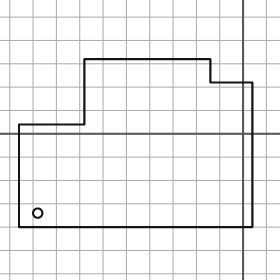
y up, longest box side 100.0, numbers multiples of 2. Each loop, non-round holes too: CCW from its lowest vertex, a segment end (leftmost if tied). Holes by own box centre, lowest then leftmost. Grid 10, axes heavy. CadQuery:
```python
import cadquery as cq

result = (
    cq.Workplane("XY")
    .moveTo(-96.0, -40.0)
    .lineTo(4.0, -40.0)
    .lineTo(4.0, 22.0)
    .lineTo(-14.0, 22.0)
    .lineTo(-14.0, 32.0)
    .lineTo(-68.0, 32.0)
    .lineTo(-68.0, 4.0)
    .lineTo(-96.0, 4.0)
    .close()
    .moveTo(-88.0, -34.0)
    .circle(2.0)
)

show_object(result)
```